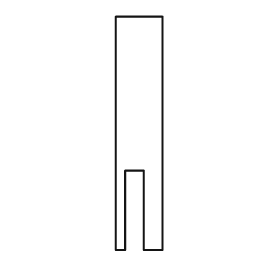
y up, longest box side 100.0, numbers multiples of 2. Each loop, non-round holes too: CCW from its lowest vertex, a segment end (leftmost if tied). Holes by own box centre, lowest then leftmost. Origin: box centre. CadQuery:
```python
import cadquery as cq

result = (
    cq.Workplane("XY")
    .moveTo(-10.0, -50.0)
    .lineTo(-6.0, -50.0)
    .lineTo(-6.0, -16.0)
    .lineTo(2.0, -16.0)
    .lineTo(2.0, -50.0)
    .lineTo(10.0, -50.0)
    .lineTo(10.0, 50.0)
    .lineTo(-10.0, 50.0)
    .close()
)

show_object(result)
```